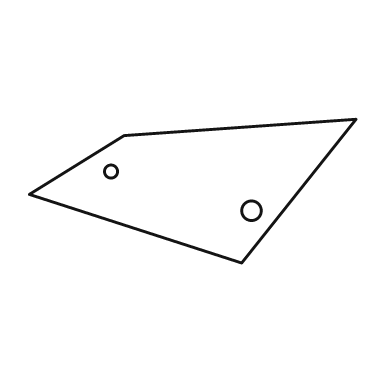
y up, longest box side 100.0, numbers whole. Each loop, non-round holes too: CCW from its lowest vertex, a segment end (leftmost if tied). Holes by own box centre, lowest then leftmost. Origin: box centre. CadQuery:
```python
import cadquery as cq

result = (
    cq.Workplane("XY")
    .moveTo(15.0, -22.0)
    .lineTo(50.0, 22.0)
    .lineTo(-21.0, 17.0)
    .lineTo(-50.0, -1.0)
    .close()
    .moveTo(18.0, -6.0)
    .circle(3.0)
    .moveTo(-25.0, 6.0)
    .circle(2.0)
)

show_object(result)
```